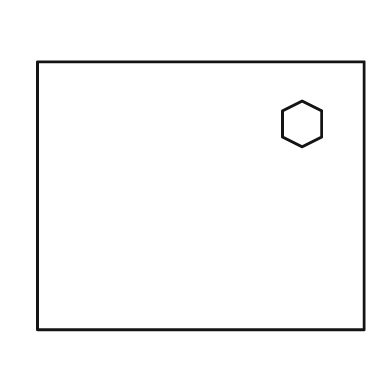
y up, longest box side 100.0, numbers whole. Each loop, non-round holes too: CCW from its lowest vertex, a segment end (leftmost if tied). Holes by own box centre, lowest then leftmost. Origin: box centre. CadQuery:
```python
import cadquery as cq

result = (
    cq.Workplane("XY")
    .moveTo(-50.0, -41.0)
    .lineTo(50.0, -41.0)
    .lineTo(50.0, 41.0)
    .lineTo(-50.0, 41.0)
    .close()
    .moveTo(31.0, 15.0)
    .lineTo(37.0, 18.0)
    .lineTo(37.0, 26.0)
    .lineTo(31.0, 29.0)
    .lineTo(25.0, 26.0)
    .lineTo(25.0, 18.0)
    .close()
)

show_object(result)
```